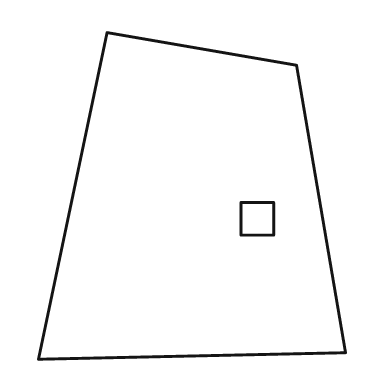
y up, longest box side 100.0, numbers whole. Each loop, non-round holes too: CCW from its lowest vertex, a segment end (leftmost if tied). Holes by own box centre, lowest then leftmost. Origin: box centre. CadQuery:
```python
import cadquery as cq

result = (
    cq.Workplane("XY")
    .moveTo(-47.0, -50.0)
    .lineTo(47.0, -48.0)
    .lineTo(32.0, 40.0)
    .lineTo(-26.0, 50.0)
    .close()
    .moveTo(15.0, -12.0)
    .lineTo(25.0, -12.0)
    .lineTo(25.0, -2.0)
    .lineTo(15.0, -2.0)
    .close()
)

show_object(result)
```